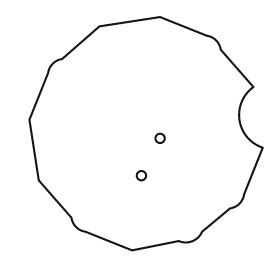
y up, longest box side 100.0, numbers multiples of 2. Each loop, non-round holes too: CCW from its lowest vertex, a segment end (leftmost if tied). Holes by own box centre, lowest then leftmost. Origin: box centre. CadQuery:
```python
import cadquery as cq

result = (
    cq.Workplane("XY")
    .moveTo(-6.0, -50.0)
    .lineTo(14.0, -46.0)
    .threePointArc((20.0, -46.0), (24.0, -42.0))
    .lineTo(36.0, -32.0)
    .threePointArc((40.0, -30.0), (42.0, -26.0))
    .lineTo(50.0, -6.0)
    .threePointArc((40.0, 6.0), (46.0, 20.0))
    .lineTo(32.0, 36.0)
    .threePointArc((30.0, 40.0), (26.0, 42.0))
    .lineTo(6.0, 50.0)
    .lineTo(-20.0, 46.0)
    .lineTo(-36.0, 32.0)
    .threePointArc((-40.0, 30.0), (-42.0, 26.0))
    .lineTo(-50.0, 6.0)
    .lineTo(-46.0, -20.0)
    .lineTo(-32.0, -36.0)
    .threePointArc((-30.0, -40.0), (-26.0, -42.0))
    .close()
    .moveTo(-2.0, -18.0)
    .circle(2.0)
    .moveTo(6.0, -2.0)
    .circle(2.0)
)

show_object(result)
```